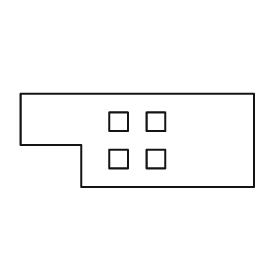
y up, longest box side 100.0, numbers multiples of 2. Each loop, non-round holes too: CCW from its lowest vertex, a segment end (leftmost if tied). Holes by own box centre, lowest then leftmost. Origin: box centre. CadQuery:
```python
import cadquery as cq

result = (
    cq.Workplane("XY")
    .moveTo(-24.0, -20.0)
    .lineTo(50.0, -20.0)
    .lineTo(50.0, 20.0)
    .lineTo(-50.0, 20.0)
    .lineTo(-50.0, -2.0)
    .lineTo(-24.0, -2.0)
    .close()
    .moveTo(-12.0, -12.0)
    .lineTo(-4.0, -12.0)
    .lineTo(-4.0, -4.0)
    .lineTo(-12.0, -4.0)
    .close()
    .moveTo(4.0, -12.0)
    .lineTo(12.0, -12.0)
    .lineTo(12.0, -4.0)
    .lineTo(4.0, -4.0)
    .close()
    .moveTo(-12.0, 4.0)
    .lineTo(-4.0, 4.0)
    .lineTo(-4.0, 12.0)
    .lineTo(-12.0, 12.0)
    .close()
    .moveTo(4.0, 4.0)
    .lineTo(12.0, 4.0)
    .lineTo(12.0, 12.0)
    .lineTo(4.0, 12.0)
    .close()
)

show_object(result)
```